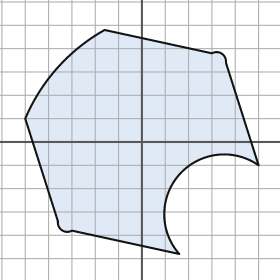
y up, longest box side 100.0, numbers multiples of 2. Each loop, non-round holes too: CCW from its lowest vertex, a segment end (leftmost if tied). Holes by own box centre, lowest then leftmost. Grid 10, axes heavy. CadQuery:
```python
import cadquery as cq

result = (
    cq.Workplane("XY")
    .moveTo(16.0, -48.0)
    .threePointArc((16.0, -14.0), (50.0, -10.0))
    .lineTo(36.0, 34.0)
    .threePointArc((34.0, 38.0), (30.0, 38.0))
    .lineTo(-16.0, 48.0)
    .threePointArc((-36.0, 32.0), (-50.0, 10.0))
    .lineTo(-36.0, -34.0)
    .threePointArc((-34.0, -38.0), (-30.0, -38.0))
    .close()
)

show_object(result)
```